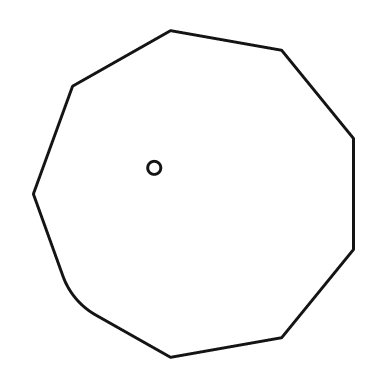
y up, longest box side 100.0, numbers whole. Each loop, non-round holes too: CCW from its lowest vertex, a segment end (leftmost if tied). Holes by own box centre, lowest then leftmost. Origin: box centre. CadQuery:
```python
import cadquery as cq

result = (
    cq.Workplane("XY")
    .moveTo(-7.0, -50.0)
    .lineTo(27.0, -44.0)
    .lineTo(49.0, -17.0)
    .lineTo(49.0, 17.0)
    .lineTo(27.0, 44.0)
    .lineTo(-7.0, 50.0)
    .lineTo(-37.0, 33.0)
    .lineTo(-49.0, 0.0)
    .lineTo(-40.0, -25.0)
    .threePointArc((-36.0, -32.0), (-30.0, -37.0))
    .close()
    .moveTo(-12.0, 8.0)
    .circle(2.0)
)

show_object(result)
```